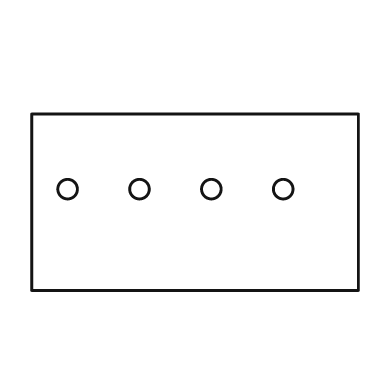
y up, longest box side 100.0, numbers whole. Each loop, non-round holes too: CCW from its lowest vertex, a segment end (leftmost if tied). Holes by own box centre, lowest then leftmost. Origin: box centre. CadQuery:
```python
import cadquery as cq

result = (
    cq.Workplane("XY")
    .moveTo(-50.0, -27.0)
    .lineTo(50.0, -27.0)
    .lineTo(50.0, 27.0)
    .lineTo(-50.0, 27.0)
    .close()
    .moveTo(-39.0, 4.0)
    .circle(3.0)
    .moveTo(-17.0, 4.0)
    .circle(3.0)
    .moveTo(5.0, 4.0)
    .circle(3.0)
    .moveTo(27.0, 4.0)
    .circle(3.0)
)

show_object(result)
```